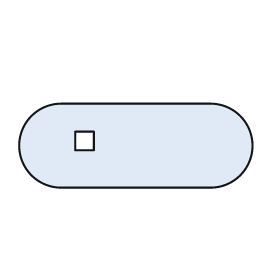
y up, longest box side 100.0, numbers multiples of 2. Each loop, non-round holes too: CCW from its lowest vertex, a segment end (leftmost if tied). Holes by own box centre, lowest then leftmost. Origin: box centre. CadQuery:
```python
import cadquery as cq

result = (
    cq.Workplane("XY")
    .moveTo(-32.0, -18.0)
    .lineTo(32.0, -18.0)
    .threePointArc((50.0, 0.0), (32.0, 18.0))
    .lineTo(-32.0, 18.0)
    .threePointArc((-50.0, 0.0), (-32.0, -18.0))
    .close()
    .moveTo(-26.0, -2.0)
    .lineTo(-18.0, -2.0)
    .lineTo(-18.0, 6.0)
    .lineTo(-26.0, 6.0)
    .close()
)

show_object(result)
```